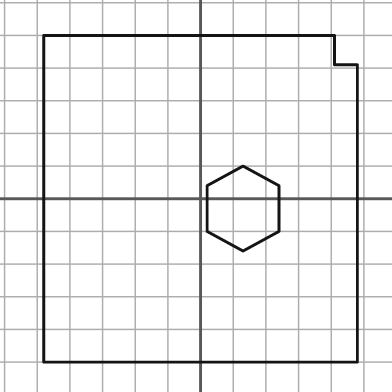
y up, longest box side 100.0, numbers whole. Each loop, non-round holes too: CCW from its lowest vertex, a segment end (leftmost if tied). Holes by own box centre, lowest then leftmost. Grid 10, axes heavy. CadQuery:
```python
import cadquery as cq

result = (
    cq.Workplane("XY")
    .moveTo(-48.0, -50.0)
    .lineTo(48.0, -50.0)
    .lineTo(48.0, 41.0)
    .lineTo(41.0, 41.0)
    .lineTo(41.0, 50.0)
    .lineTo(-48.0, 50.0)
    .close()
    .moveTo(13.0, -16.0)
    .lineTo(24.0, -10.0)
    .lineTo(24.0, 4.0)
    .lineTo(13.0, 10.0)
    .lineTo(2.0, 4.0)
    .lineTo(2.0, -10.0)
    .close()
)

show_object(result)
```